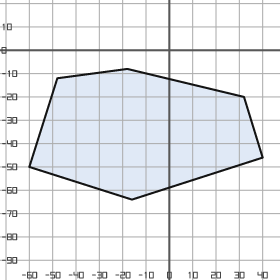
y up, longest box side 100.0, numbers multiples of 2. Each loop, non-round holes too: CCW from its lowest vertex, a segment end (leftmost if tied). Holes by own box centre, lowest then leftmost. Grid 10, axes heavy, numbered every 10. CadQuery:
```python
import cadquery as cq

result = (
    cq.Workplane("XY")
    .moveTo(-16.0, -64.0)
    .lineTo(40.0, -46.0)
    .lineTo(32.0, -20.0)
    .lineTo(-18.0, -8.0)
    .lineTo(-48.0, -12.0)
    .lineTo(-60.0, -50.0)
    .close()
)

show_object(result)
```